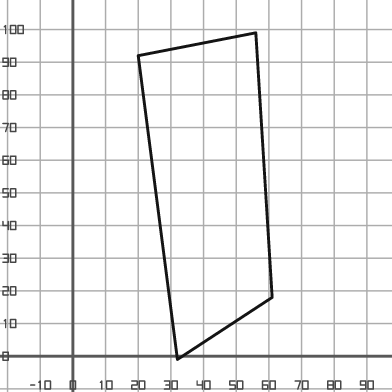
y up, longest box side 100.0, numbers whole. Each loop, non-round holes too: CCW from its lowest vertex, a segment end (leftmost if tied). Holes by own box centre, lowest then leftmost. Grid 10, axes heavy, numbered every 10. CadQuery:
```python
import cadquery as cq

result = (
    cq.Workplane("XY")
    .moveTo(32.0, -1.0)
    .lineTo(61.0, 18.0)
    .lineTo(56.0, 99.0)
    .lineTo(20.0, 92.0)
    .close()
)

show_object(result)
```